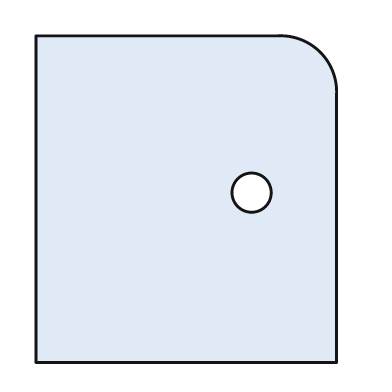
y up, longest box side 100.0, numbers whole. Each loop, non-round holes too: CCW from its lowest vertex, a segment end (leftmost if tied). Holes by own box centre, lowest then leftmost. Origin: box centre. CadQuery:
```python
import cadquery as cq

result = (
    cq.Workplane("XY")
    .moveTo(-46.0, -50.0)
    .lineTo(46.0, -50.0)
    .lineTo(46.0, 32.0)
    .threePointArc((41.0, 45.0), (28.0, 50.0))
    .lineTo(-46.0, 50.0)
    .close()
    .moveTo(20.0, 2.0)
    .circle(6.0)
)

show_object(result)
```